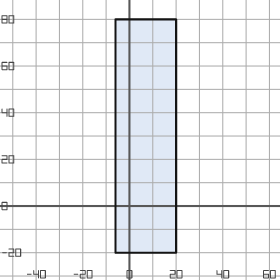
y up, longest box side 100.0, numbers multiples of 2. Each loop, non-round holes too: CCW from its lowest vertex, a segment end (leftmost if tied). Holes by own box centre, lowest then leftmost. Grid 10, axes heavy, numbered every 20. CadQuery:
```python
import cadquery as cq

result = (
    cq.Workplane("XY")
    .moveTo(-6.0, -20.0)
    .lineTo(20.0, -20.0)
    .lineTo(20.0, 80.0)
    .lineTo(-6.0, 80.0)
    .close()
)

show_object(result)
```